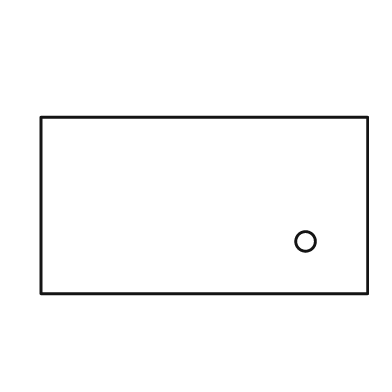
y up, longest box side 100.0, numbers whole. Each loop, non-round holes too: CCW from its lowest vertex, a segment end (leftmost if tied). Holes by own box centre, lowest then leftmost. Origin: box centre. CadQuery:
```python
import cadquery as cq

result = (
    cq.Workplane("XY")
    .moveTo(-50.0, -27.0)
    .lineTo(50.0, -27.0)
    .lineTo(50.0, 27.0)
    .lineTo(-50.0, 27.0)
    .close()
    .moveTo(31.0, -11.0)
    .circle(3.0)
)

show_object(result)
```